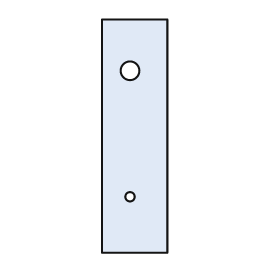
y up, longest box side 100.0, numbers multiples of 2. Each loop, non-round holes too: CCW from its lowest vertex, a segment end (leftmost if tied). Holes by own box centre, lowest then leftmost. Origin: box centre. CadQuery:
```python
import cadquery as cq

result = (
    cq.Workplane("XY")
    .moveTo(-14.0, -50.0)
    .lineTo(14.0, -50.0)
    .lineTo(14.0, 50.0)
    .lineTo(-14.0, 50.0)
    .close()
    .moveTo(-2.0, -26.0)
    .circle(2.0)
    .moveTo(-2.0, 28.0)
    .circle(4.0)
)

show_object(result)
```